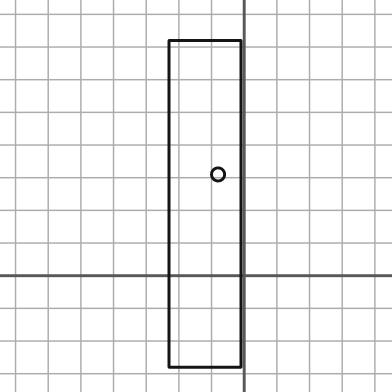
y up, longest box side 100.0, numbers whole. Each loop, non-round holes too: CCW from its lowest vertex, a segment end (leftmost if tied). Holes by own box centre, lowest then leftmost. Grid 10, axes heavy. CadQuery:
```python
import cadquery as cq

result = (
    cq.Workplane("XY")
    .moveTo(-23.0, -28.0)
    .lineTo(-1.0, -28.0)
    .lineTo(-1.0, 72.0)
    .lineTo(-23.0, 72.0)
    .close()
    .moveTo(-8.0, 31.0)
    .circle(2.0)
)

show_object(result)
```